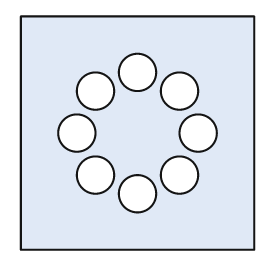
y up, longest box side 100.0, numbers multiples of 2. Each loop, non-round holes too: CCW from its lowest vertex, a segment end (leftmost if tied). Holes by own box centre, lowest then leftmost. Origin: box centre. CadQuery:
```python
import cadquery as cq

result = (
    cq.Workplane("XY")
    .moveTo(-50.0, -50.0)
    .lineTo(50.0, -50.0)
    .lineTo(50.0, 50.0)
    .lineTo(-50.0, 50.0)
    .close()
    .moveTo(0.0, -26.0)
    .circle(8.0)
    .moveTo(-18.0, -18.0)
    .circle(8.0)
    .moveTo(18.0, -18.0)
    .circle(8.0)
    .moveTo(-26.0, 0.0)
    .circle(8.0)
    .moveTo(26.0, 0.0)
    .circle(8.0)
    .moveTo(-18.0, 18.0)
    .circle(8.0)
    .moveTo(18.0, 18.0)
    .circle(8.0)
    .moveTo(0.0, 26.0)
    .circle(8.0)
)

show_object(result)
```